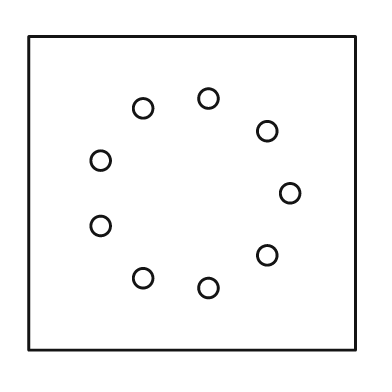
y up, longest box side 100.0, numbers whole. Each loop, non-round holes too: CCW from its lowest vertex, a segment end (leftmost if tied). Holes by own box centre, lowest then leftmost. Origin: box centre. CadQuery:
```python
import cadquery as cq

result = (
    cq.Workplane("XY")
    .moveTo(-50.0, -48.0)
    .lineTo(50.0, -48.0)
    .lineTo(50.0, 48.0)
    .lineTo(-50.0, 48.0)
    .close()
    .moveTo(5.0, -29.0)
    .circle(3.0)
    .moveTo(-15.0, -26.0)
    .circle(3.0)
    .moveTo(23.0, -19.0)
    .circle(3.0)
    .moveTo(-28.0, -10.0)
    .circle(3.0)
    .moveTo(30.0, 0.0)
    .circle(3.0)
    .moveTo(-28.0, 10.0)
    .circle(3.0)
    .moveTo(23.0, 19.0)
    .circle(3.0)
    .moveTo(-15.0, 26.0)
    .circle(3.0)
    .moveTo(5.0, 29.0)
    .circle(3.0)
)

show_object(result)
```